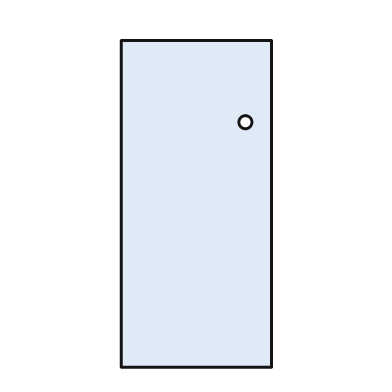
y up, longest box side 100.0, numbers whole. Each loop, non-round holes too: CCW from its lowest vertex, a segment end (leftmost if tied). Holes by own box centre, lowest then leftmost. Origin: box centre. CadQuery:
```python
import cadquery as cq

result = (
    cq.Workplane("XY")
    .moveTo(-23.0, -50.0)
    .lineTo(23.0, -50.0)
    .lineTo(23.0, 50.0)
    .lineTo(-23.0, 50.0)
    .close()
    .moveTo(15.0, 25.0)
    .circle(2.0)
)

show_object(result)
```